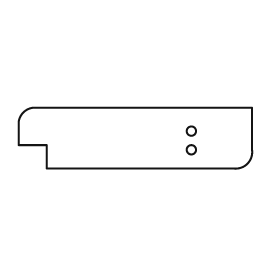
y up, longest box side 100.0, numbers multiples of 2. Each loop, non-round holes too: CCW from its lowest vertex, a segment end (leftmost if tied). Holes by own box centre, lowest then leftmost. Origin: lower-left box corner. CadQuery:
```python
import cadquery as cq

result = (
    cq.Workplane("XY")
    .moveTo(12.0, 0.0)
    .lineTo(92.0, 0.0)
    .threePointArc((98.0, 2.0), (100.0, 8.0))
    .lineTo(100.0, 26.0)
    .lineTo(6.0, 26.0)
    .threePointArc((2.0, 24.0), (0.0, 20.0))
    .lineTo(0.0, 10.0)
    .lineTo(12.0, 10.0)
    .close()
    .moveTo(74.0, 8.0)
    .circle(2.0)
    .moveTo(74.0, 16.0)
    .circle(2.0)
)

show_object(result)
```